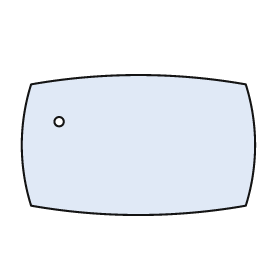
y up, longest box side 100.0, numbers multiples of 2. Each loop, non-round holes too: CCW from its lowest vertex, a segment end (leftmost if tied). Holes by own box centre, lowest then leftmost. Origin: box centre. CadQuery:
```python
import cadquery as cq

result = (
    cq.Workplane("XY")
    .moveTo(-46.0, -26.0)
    .threePointArc((0.0, -30.0), (46.0, -26.0))
    .threePointArc((50.0, 0.0), (46.0, 26.0))
    .threePointArc((0.0, 30.0), (-46.0, 26.0))
    .threePointArc((-50.0, 0.0), (-46.0, -26.0))
    .close()
    .moveTo(-34.0, 10.0)
    .circle(2.0)
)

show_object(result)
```